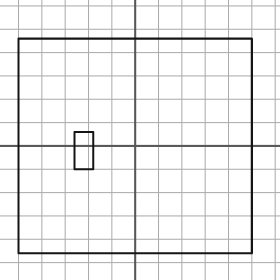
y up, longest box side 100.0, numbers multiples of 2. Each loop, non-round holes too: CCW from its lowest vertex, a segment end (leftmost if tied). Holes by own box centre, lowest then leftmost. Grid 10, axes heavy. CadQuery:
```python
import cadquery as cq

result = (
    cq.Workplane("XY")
    .moveTo(-50.0, -46.0)
    .lineTo(50.0, -46.0)
    .lineTo(50.0, 46.0)
    .lineTo(-50.0, 46.0)
    .close()
    .moveTo(-26.0, -10.0)
    .lineTo(-18.0, -10.0)
    .lineTo(-18.0, 6.0)
    .lineTo(-26.0, 6.0)
    .close()
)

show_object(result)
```